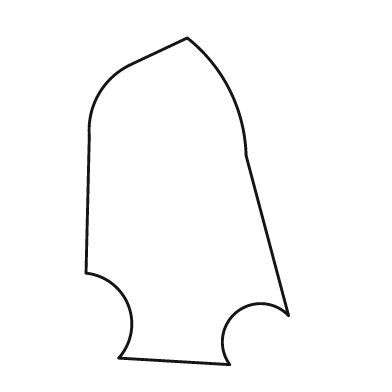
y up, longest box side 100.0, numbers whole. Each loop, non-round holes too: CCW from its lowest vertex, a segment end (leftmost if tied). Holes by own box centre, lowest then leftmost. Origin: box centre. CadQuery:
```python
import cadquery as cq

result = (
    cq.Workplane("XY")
    .moveTo(13.0, -50.0)
    .threePointArc((15.0, -34.0), (31.0, -35.0))
    .lineTo(18.0, 14.0)
    .threePointArc((13.0, 34.0), (0.0, 50.0))
    .lineTo(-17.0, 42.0)
    .threePointArc((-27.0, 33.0), (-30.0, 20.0))
    .lineTo(-31.0, -22.0)
    .threePointArc((-18.0, -32.0), (-21.0, -48.0))
    .close()
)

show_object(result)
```